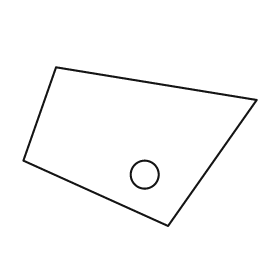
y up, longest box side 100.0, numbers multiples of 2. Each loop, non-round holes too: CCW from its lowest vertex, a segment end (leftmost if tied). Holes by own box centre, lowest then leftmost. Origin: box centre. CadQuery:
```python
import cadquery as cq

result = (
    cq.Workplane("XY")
    .moveTo(12.0, -34.0)
    .lineTo(50.0, 20.0)
    .lineTo(-36.0, 34.0)
    .lineTo(-50.0, -6.0)
    .close()
    .moveTo(2.0, -12.0)
    .circle(6.0)
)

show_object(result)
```